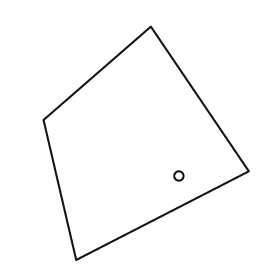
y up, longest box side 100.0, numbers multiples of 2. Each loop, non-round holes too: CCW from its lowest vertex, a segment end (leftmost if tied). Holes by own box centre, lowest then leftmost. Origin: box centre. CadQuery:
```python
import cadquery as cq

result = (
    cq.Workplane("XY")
    .moveTo(-30.0, -50.0)
    .lineTo(44.0, -12.0)
    .lineTo(2.0, 50.0)
    .lineTo(-44.0, 10.0)
    .close()
    .moveTo(14.0, -14.0)
    .circle(2.0)
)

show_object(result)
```